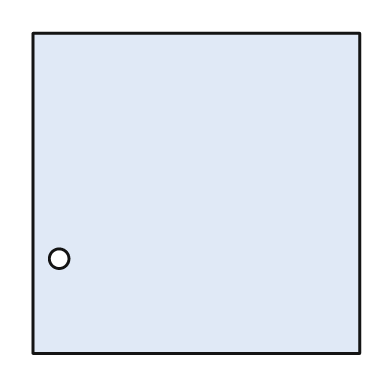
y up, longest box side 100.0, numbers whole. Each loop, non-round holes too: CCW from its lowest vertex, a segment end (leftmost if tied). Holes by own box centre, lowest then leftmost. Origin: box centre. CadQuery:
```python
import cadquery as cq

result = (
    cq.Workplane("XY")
    .moveTo(-50.0, -49.0)
    .lineTo(50.0, -49.0)
    .lineTo(50.0, 49.0)
    .lineTo(-50.0, 49.0)
    .close()
    .moveTo(-42.0, -20.0)
    .circle(3.0)
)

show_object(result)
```